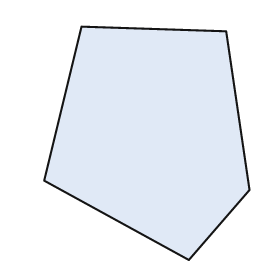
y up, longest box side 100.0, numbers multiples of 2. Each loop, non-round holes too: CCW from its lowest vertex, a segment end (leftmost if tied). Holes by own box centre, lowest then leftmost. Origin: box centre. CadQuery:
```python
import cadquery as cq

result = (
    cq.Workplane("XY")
    .moveTo(18.0, -50.0)
    .lineTo(44.0, -20.0)
    .lineTo(34.0, 48.0)
    .lineTo(-28.0, 50.0)
    .lineTo(-44.0, -16.0)
    .close()
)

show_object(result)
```